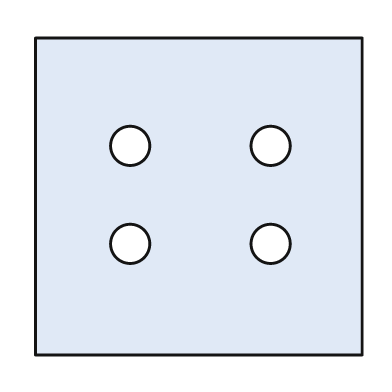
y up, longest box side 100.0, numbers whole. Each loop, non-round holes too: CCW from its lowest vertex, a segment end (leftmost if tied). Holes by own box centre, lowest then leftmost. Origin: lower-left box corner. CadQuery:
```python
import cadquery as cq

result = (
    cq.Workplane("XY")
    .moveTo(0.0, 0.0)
    .lineTo(100.0, 0.0)
    .lineTo(100.0, 97.0)
    .lineTo(0.0, 97.0)
    .close()
    .moveTo(29.0, 34.0)
    .circle(6.0)
    .moveTo(72.0, 34.0)
    .circle(6.0)
    .moveTo(29.0, 64.0)
    .circle(6.0)
    .moveTo(72.0, 64.0)
    .circle(6.0)
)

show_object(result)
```